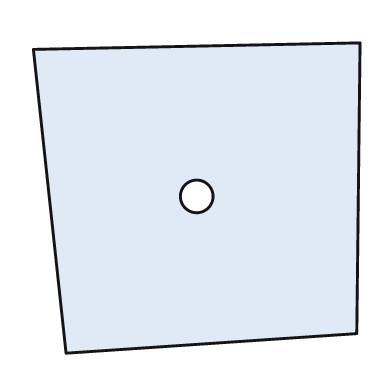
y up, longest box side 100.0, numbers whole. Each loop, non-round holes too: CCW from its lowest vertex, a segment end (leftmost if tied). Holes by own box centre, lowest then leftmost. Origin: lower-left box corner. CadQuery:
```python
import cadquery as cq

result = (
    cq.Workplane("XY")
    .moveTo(10.0, 0.0)
    .lineTo(99.0, 6.0)
    .lineTo(100.0, 95.0)
    .lineTo(0.0, 93.0)
    .close()
    .moveTo(50.0, 48.0)
    .circle(5.0)
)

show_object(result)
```